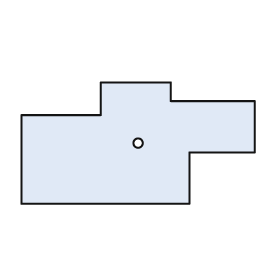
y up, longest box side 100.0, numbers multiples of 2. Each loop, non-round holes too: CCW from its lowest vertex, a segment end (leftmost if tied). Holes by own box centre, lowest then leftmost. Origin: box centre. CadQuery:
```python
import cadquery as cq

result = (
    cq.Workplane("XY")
    .moveTo(-50.0, -26.0)
    .lineTo(22.0, -26.0)
    .lineTo(22.0, -4.0)
    .lineTo(50.0, -4.0)
    .lineTo(50.0, 18.0)
    .lineTo(14.0, 18.0)
    .lineTo(14.0, 26.0)
    .lineTo(-16.0, 26.0)
    .lineTo(-16.0, 12.0)
    .lineTo(-50.0, 12.0)
    .close()
    .moveTo(0.0, 0.0)
    .circle(2.0)
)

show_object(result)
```